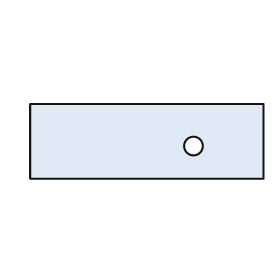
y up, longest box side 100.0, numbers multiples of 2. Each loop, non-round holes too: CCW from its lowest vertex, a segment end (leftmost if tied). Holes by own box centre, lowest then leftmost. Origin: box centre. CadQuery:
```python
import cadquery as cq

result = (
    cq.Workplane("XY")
    .moveTo(-50.0, -16.0)
    .lineTo(50.0, -16.0)
    .lineTo(50.0, 16.0)
    .lineTo(-50.0, 16.0)
    .close()
    .moveTo(20.0, -2.0)
    .circle(4.0)
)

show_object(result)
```